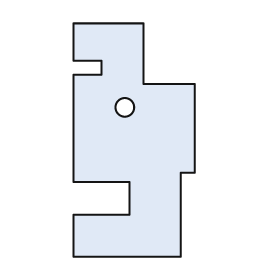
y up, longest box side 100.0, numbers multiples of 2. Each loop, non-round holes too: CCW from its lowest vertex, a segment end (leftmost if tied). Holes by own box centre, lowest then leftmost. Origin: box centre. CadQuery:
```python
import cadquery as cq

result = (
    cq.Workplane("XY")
    .moveTo(-26.0, -50.0)
    .lineTo(20.0, -50.0)
    .lineTo(20.0, -14.0)
    .lineTo(26.0, -14.0)
    .lineTo(26.0, 24.0)
    .lineTo(4.0, 24.0)
    .lineTo(4.0, 50.0)
    .lineTo(-26.0, 50.0)
    .lineTo(-26.0, 34.0)
    .lineTo(-14.0, 34.0)
    .lineTo(-14.0, 28.0)
    .lineTo(-26.0, 28.0)
    .lineTo(-26.0, -18.0)
    .lineTo(-2.0, -18.0)
    .lineTo(-2.0, -32.0)
    .lineTo(-26.0, -32.0)
    .close()
    .moveTo(-4.0, 14.0)
    .circle(4.0)
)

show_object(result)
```